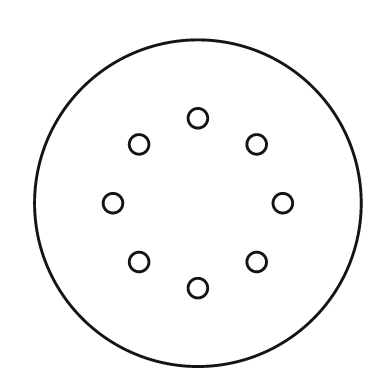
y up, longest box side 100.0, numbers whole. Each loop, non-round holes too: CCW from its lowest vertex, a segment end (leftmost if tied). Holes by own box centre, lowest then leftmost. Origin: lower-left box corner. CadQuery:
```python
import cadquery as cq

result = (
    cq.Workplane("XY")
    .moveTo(50.0, 50.0)
    .circle(50.0)
    .moveTo(50.0, 24.0)
    .circle(3.0)
    .moveTo(32.0, 32.0)
    .circle(3.0)
    .moveTo(68.0, 32.0)
    .circle(3.0)
    .moveTo(24.0, 50.0)
    .circle(3.0)
    .moveTo(76.0, 50.0)
    .circle(3.0)
    .moveTo(32.0, 68.0)
    .circle(3.0)
    .moveTo(68.0, 68.0)
    .circle(3.0)
    .moveTo(50.0, 76.0)
    .circle(3.0)
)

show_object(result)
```